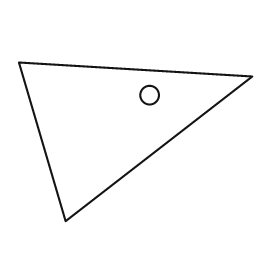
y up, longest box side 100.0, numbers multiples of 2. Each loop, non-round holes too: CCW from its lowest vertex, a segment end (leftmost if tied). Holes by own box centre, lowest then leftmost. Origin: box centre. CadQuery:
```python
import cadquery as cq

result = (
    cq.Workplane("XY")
    .moveTo(-30.0, -34.0)
    .lineTo(50.0, 28.0)
    .lineTo(-50.0, 34.0)
    .close()
    .moveTo(6.0, 20.0)
    .circle(4.0)
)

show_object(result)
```